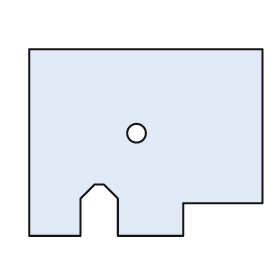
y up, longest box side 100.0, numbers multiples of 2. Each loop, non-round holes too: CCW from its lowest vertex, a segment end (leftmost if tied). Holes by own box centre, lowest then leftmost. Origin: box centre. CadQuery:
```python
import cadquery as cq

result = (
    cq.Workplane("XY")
    .moveTo(-50.0, -40.0)
    .lineTo(-28.0, -40.0)
    .lineTo(-28.0, -24.0)
    .lineTo(-22.0, -18.0)
    .lineTo(-18.0, -18.0)
    .lineTo(-12.0, -24.0)
    .lineTo(-12.0, -40.0)
    .lineTo(16.0, -40.0)
    .lineTo(16.0, -26.0)
    .lineTo(50.0, -26.0)
    .lineTo(50.0, 40.0)
    .lineTo(-50.0, 40.0)
    .close()
    .moveTo(-4.0, 4.0)
    .circle(4.0)
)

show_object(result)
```